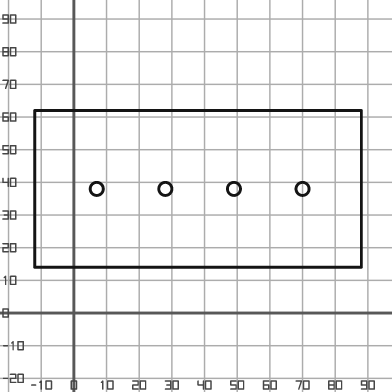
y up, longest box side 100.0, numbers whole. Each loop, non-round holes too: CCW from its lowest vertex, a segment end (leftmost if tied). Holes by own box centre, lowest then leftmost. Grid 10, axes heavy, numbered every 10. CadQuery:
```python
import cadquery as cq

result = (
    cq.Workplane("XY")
    .moveTo(-12.0, 14.0)
    .lineTo(88.0, 14.0)
    .lineTo(88.0, 62.0)
    .lineTo(-12.0, 62.0)
    .close()
    .moveTo(7.0, 38.0)
    .circle(2.0)
    .moveTo(28.0, 38.0)
    .circle(2.0)
    .moveTo(49.0, 38.0)
    .circle(2.0)
    .moveTo(70.0, 38.0)
    .circle(2.0)
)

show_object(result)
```